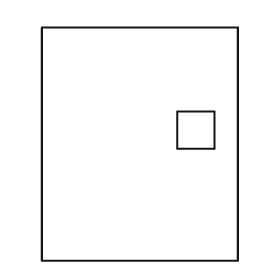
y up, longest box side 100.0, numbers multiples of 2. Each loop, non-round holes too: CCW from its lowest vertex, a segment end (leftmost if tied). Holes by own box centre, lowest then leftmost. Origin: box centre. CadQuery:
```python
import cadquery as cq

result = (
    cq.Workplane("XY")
    .moveTo(-42.0, -50.0)
    .lineTo(42.0, -50.0)
    .lineTo(42.0, 50.0)
    .lineTo(-42.0, 50.0)
    .close()
    .moveTo(16.0, -2.0)
    .lineTo(32.0, -2.0)
    .lineTo(32.0, 14.0)
    .lineTo(16.0, 14.0)
    .close()
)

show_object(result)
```